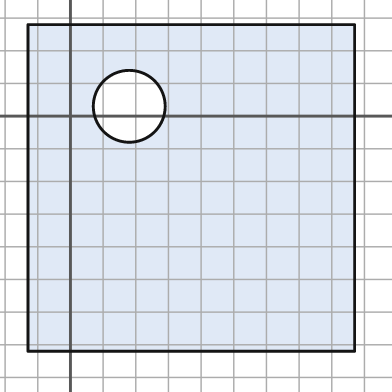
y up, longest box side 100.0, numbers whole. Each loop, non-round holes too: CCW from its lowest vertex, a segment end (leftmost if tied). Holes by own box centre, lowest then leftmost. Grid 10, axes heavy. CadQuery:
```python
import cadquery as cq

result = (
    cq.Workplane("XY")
    .moveTo(-13.0, -72.0)
    .lineTo(87.0, -72.0)
    .lineTo(87.0, 28.0)
    .lineTo(-13.0, 28.0)
    .close()
    .moveTo(18.0, 3.0)
    .circle(11.0)
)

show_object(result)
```